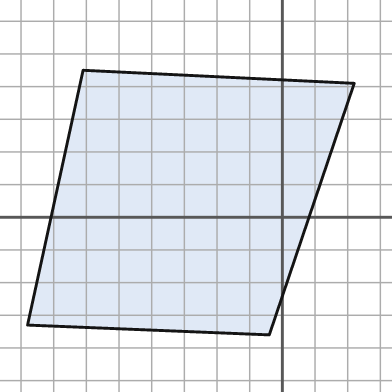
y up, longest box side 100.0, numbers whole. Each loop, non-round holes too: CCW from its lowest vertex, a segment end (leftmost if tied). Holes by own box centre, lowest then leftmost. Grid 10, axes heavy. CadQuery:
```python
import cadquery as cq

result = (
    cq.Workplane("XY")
    .moveTo(-4.0, -36.0)
    .lineTo(22.0, 41.0)
    .lineTo(-61.0, 45.0)
    .lineTo(-78.0, -33.0)
    .close()
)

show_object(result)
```